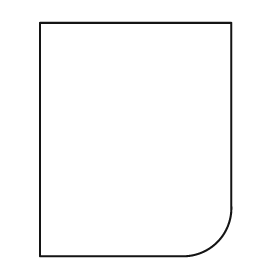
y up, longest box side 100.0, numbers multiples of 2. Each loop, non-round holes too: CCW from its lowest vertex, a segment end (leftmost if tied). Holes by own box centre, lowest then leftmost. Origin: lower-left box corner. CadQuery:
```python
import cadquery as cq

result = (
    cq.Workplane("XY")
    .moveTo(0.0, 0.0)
    .lineTo(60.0, 0.0)
    .threePointArc((76.0, 6.0), (82.0, 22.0))
    .lineTo(82.0, 100.0)
    .lineTo(0.0, 100.0)
    .close()
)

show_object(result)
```